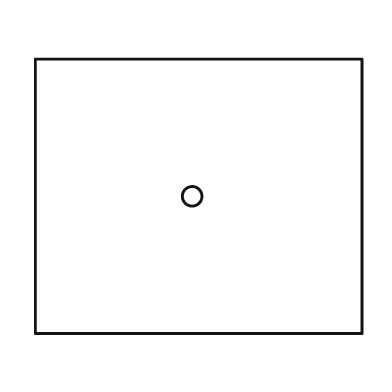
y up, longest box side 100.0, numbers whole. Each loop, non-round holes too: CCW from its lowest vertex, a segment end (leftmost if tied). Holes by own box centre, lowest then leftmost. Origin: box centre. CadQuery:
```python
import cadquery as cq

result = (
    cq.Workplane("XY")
    .moveTo(-50.0, -42.0)
    .lineTo(50.0, -42.0)
    .lineTo(50.0, 42.0)
    .lineTo(-50.0, 42.0)
    .close()
    .moveTo(-2.0, 0.0)
    .circle(3.0)
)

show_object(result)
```